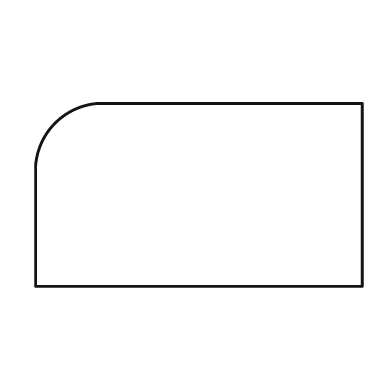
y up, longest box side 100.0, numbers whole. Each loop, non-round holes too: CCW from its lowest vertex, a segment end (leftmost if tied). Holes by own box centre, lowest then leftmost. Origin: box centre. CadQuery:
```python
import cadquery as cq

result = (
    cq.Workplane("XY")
    .moveTo(-50.0, -28.0)
    .lineTo(50.0, -28.0)
    .lineTo(50.0, 28.0)
    .lineTo(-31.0, 28.0)
    .threePointArc((-44.0, 22.0), (-50.0, 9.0))
    .close()
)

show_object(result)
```